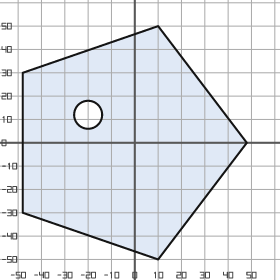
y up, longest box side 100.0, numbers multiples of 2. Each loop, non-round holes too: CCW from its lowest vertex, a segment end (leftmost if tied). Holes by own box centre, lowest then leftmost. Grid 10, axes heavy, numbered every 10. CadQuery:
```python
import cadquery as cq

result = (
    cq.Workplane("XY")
    .moveTo(10.0, -50.0)
    .lineTo(48.0, 0.0)
    .lineTo(10.0, 50.0)
    .lineTo(-48.0, 30.0)
    .lineTo(-48.0, -30.0)
    .close()
    .moveTo(-20.0, 12.0)
    .circle(6.0)
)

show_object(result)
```